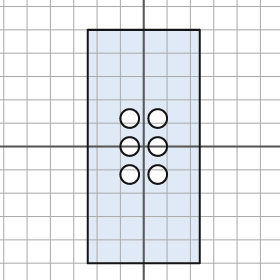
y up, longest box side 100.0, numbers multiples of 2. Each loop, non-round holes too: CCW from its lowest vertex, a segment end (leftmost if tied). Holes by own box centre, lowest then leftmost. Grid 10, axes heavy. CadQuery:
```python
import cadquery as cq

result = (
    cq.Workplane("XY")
    .moveTo(-24.0, -50.0)
    .lineTo(24.0, -50.0)
    .lineTo(24.0, 50.0)
    .lineTo(-24.0, 50.0)
    .close()
    .moveTo(-6.0, -12.0)
    .circle(4.0)
    .moveTo(6.0, -12.0)
    .circle(4.0)
    .moveTo(-6.0, 0.0)
    .circle(4.0)
    .moveTo(6.0, 0.0)
    .circle(4.0)
    .moveTo(-6.0, 12.0)
    .circle(4.0)
    .moveTo(6.0, 12.0)
    .circle(4.0)
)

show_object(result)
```